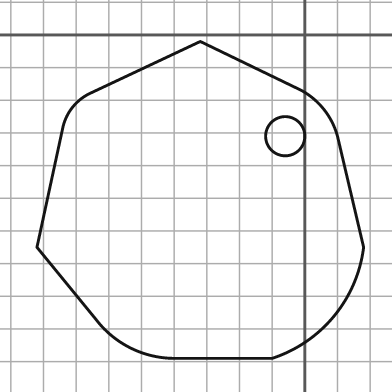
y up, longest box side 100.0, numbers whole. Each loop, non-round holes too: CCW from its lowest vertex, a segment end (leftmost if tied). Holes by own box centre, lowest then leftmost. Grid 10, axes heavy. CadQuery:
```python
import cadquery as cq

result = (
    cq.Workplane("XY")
    .moveTo(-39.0, -99.0)
    .lineTo(-10.0, -99.0)
    .threePointArc((9.0, -86.0), (18.0, -65.0))
    .lineTo(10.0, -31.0)
    .threePointArc((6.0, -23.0), (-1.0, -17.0))
    .lineTo(-32.0, -2.0)
    .lineTo(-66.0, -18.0)
    .threePointArc((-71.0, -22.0), (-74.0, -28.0))
    .lineTo(-82.0, -65.0)
    .lineTo(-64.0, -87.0)
    .threePointArc((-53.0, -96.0), (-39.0, -99.0))
    .close()
    .moveTo(-6.0, -31.0)
    .circle(6.0)
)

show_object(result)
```